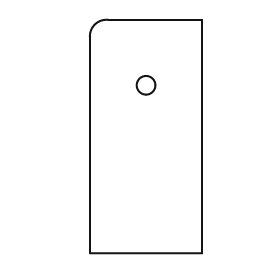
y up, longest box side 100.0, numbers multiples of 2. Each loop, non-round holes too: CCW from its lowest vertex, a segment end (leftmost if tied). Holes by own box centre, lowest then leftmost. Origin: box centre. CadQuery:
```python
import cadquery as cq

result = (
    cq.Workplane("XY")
    .moveTo(-24.0, -50.0)
    .lineTo(24.0, -50.0)
    .lineTo(24.0, 50.0)
    .lineTo(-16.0, 50.0)
    .threePointArc((-22.0, 48.0), (-24.0, 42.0))
    .close()
    .moveTo(0.0, 22.0)
    .circle(4.0)
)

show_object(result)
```